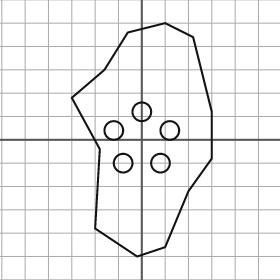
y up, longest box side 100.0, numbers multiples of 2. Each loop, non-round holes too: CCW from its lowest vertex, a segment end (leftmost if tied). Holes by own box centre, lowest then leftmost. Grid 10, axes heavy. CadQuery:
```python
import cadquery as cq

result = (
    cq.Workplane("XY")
    .moveTo(-2.0, -50.0)
    .lineTo(10.0, -46.0)
    .lineTo(20.0, -22.0)
    .lineTo(30.0, -8.0)
    .lineTo(30.0, 12.0)
    .lineTo(22.0, 44.0)
    .lineTo(10.0, 50.0)
    .lineTo(-6.0, 46.0)
    .lineTo(-16.0, 30.0)
    .lineTo(-30.0, 18.0)
    .lineTo(-18.0, -4.0)
    .lineTo(-20.0, -38.0)
    .close()
    .moveTo(-8.0, -10.0)
    .circle(4.0)
    .moveTo(8.0, -10.0)
    .circle(4.0)
    .moveTo(-12.0, 4.0)
    .circle(4.0)
    .moveTo(12.0, 4.0)
    .circle(4.0)
    .moveTo(0.0, 12.0)
    .circle(4.0)
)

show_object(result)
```